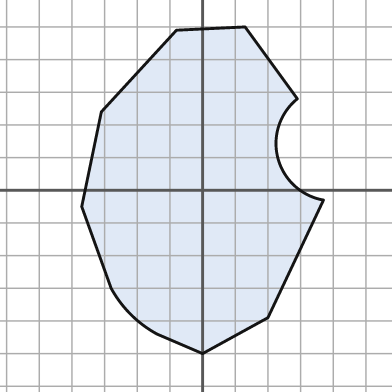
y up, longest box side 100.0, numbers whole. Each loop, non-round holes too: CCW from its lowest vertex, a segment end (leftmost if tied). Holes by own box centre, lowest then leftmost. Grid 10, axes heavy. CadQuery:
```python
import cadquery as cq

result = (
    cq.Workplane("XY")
    .moveTo(0.0, -50.0)
    .lineTo(20.0, -39.0)
    .lineTo(37.0, -3.0)
    .threePointArc((23.0, 10.0), (29.0, 28.0))
    .lineTo(13.0, 50.0)
    .lineTo(-8.0, 49.0)
    .lineTo(-31.0, 24.0)
    .lineTo(-37.0, -5.0)
    .lineTo(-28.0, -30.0)
    .threePointArc((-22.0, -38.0), (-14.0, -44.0))
    .close()
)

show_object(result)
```